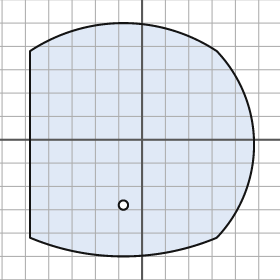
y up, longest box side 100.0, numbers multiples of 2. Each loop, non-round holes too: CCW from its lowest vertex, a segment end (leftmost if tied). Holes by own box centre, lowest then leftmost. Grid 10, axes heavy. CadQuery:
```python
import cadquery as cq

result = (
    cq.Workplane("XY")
    .moveTo(-48.0, -42.0)
    .threePointArc((-8.0, -50.0), (32.0, -42.0))
    .threePointArc((48.0, -2.0), (32.0, 38.0))
    .threePointArc((-8.0, 50.0), (-48.0, 38.0))
    .close()
    .moveTo(-8.0, -28.0)
    .circle(2.0)
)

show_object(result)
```